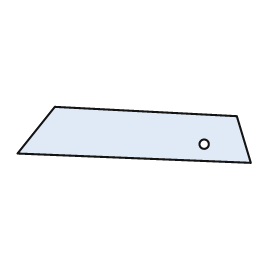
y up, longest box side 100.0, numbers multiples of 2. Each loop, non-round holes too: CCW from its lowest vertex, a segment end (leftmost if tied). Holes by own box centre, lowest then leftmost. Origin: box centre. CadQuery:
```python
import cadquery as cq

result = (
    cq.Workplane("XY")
    .moveTo(50.0, -12.0)
    .lineTo(44.0, 8.0)
    .lineTo(-34.0, 12.0)
    .lineTo(-50.0, -8.0)
    .close()
    .moveTo(30.0, -4.0)
    .circle(2.0)
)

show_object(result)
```